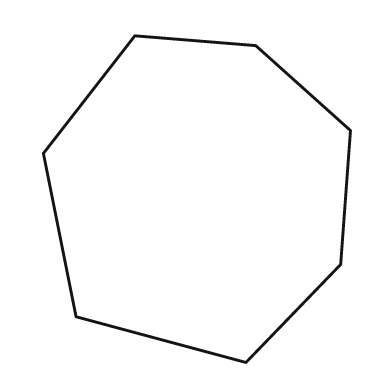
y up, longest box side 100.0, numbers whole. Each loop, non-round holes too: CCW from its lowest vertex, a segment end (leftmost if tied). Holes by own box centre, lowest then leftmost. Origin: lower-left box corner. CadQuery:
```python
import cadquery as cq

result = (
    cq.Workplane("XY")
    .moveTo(62.0, 0.0)
    .lineTo(91.0, 30.0)
    .lineTo(94.0, 71.0)
    .lineTo(65.0, 97.0)
    .lineTo(28.0, 100.0)
    .lineTo(0.0, 64.0)
    .lineTo(10.0, 14.0)
    .close()
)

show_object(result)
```